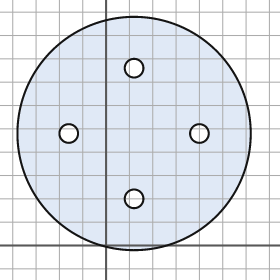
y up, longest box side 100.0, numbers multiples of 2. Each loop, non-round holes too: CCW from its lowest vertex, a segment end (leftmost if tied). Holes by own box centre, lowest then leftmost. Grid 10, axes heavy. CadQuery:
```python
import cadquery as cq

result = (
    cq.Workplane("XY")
    .moveTo(12.0, 48.0)
    .circle(50.0)
    .moveTo(12.0, 20.0)
    .circle(4.0)
    .moveTo(-16.0, 48.0)
    .circle(4.0)
    .moveTo(40.0, 48.0)
    .circle(4.0)
    .moveTo(12.0, 76.0)
    .circle(4.0)
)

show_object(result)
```